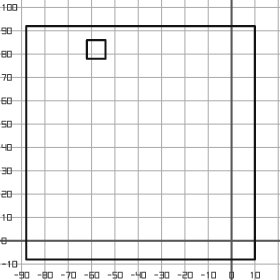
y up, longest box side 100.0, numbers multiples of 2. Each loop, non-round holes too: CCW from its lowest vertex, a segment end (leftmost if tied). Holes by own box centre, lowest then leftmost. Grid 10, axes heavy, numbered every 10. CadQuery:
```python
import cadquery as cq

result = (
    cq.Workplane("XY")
    .moveTo(-88.0, -8.0)
    .lineTo(10.0, -8.0)
    .lineTo(10.0, 92.0)
    .lineTo(-88.0, 92.0)
    .close()
    .moveTo(-62.0, 78.0)
    .lineTo(-54.0, 78.0)
    .lineTo(-54.0, 86.0)
    .lineTo(-62.0, 86.0)
    .close()
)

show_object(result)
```